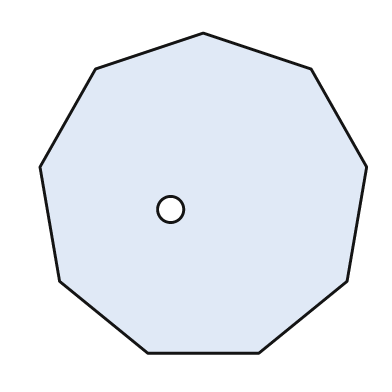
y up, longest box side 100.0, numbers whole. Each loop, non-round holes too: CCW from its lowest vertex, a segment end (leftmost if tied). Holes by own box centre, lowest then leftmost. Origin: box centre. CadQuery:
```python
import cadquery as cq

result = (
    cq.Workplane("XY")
    .moveTo(-17.0, -49.0)
    .lineTo(17.0, -49.0)
    .lineTo(44.0, -27.0)
    .lineTo(50.0, 8.0)
    .lineTo(33.0, 38.0)
    .lineTo(0.0, 49.0)
    .lineTo(-33.0, 38.0)
    .lineTo(-50.0, 8.0)
    .lineTo(-44.0, -27.0)
    .close()
    .moveTo(-10.0, -5.0)
    .circle(4.0)
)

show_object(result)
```